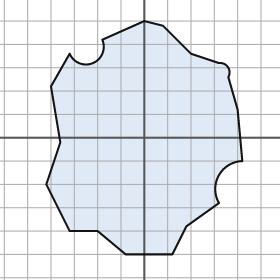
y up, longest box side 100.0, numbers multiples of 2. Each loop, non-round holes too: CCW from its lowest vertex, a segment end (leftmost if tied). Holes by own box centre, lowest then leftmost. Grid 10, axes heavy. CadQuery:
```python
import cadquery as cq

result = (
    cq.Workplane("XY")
    .moveTo(-8.0, -50.0)
    .lineTo(12.0, -50.0)
    .lineTo(18.0, -38.0)
    .lineTo(32.0, -28.0)
    .threePointArc((32.0, -16.0), (42.0, -10.0))
    .lineTo(40.0, 12.0)
    .lineTo(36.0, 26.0)
    .threePointArc((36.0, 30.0), (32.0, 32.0))
    .lineTo(20.0, 36.0)
    .lineTo(8.0, 48.0)
    .lineTo(0.0, 50.0)
    .lineTo(-18.0, 42.0)
    .threePointArc((-22.0, 32.0), (-32.0, 36.0))
    .lineTo(-40.0, 22.0)
    .lineTo(-36.0, -2.0)
    .lineTo(-42.0, -20.0)
    .lineTo(-32.0, -40.0)
    .lineTo(-20.0, -40.0)
    .close()
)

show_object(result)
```